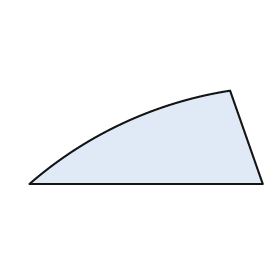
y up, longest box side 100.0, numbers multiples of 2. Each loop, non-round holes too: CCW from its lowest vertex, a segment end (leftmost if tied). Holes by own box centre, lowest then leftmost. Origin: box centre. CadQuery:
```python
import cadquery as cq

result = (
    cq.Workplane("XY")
    .moveTo(-50.0, -20.0)
    .lineTo(50.0, -20.0)
    .lineTo(36.0, 20.0)
    .threePointArc((-10.0, 6.0), (-50.0, -20.0))
    .close()
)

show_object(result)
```